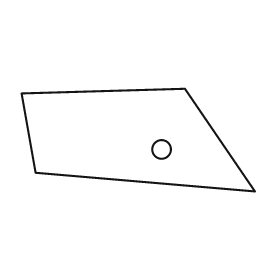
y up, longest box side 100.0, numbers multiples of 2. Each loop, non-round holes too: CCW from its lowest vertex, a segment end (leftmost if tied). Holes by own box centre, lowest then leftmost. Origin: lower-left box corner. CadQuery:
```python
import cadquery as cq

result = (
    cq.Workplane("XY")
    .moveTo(100.0, 0.0)
    .lineTo(70.0, 44.0)
    .lineTo(0.0, 42.0)
    .lineTo(6.0, 8.0)
    .close()
    .moveTo(60.0, 18.0)
    .circle(4.0)
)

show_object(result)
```